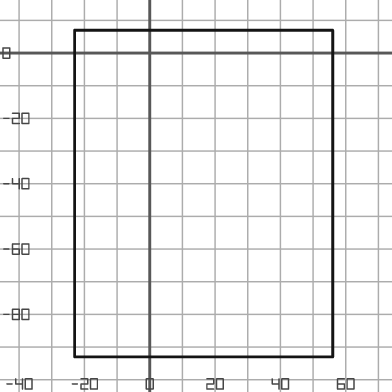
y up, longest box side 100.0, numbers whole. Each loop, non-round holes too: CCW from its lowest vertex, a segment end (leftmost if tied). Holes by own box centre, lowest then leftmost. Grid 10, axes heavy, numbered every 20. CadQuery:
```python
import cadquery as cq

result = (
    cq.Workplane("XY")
    .moveTo(-23.0, -93.0)
    .lineTo(56.0, -93.0)
    .lineTo(56.0, 7.0)
    .lineTo(-23.0, 7.0)
    .close()
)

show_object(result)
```